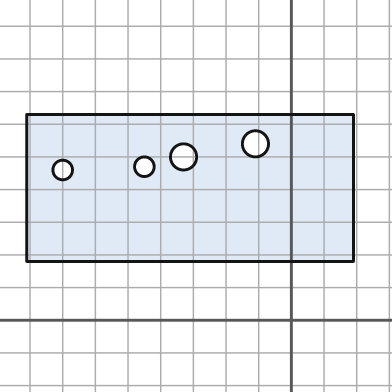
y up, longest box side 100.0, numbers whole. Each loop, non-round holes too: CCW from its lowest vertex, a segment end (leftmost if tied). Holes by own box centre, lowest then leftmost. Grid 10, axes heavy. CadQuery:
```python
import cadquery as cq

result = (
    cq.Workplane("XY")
    .moveTo(-81.0, 18.0)
    .lineTo(19.0, 18.0)
    .lineTo(19.0, 63.0)
    .lineTo(-81.0, 63.0)
    .close()
    .moveTo(-70.0, 46.0)
    .circle(3.0)
    .moveTo(-45.0, 47.0)
    .circle(3.0)
    .moveTo(-33.0, 50.0)
    .circle(4.0)
    .moveTo(-11.0, 54.0)
    .circle(4.0)
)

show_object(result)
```